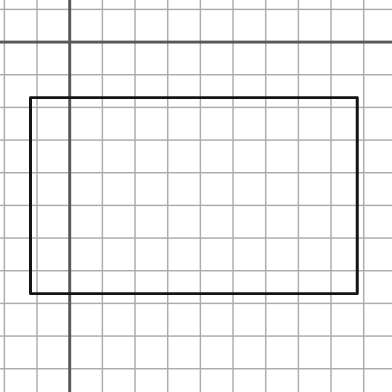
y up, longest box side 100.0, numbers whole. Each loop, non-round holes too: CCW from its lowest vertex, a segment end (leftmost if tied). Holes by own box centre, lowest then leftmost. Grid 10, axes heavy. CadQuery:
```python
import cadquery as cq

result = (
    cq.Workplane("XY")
    .moveTo(-12.0, -77.0)
    .lineTo(88.0, -77.0)
    .lineTo(88.0, -17.0)
    .lineTo(-12.0, -17.0)
    .close()
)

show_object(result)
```